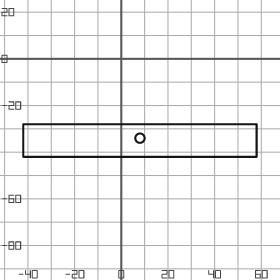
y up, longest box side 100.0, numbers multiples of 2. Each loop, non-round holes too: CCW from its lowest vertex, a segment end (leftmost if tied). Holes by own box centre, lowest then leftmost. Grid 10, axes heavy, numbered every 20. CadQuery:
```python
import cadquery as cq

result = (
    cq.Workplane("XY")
    .moveTo(-42.0, -42.0)
    .lineTo(58.0, -42.0)
    .lineTo(58.0, -28.0)
    .lineTo(-42.0, -28.0)
    .close()
    .moveTo(8.0, -34.0)
    .circle(2.0)
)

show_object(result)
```